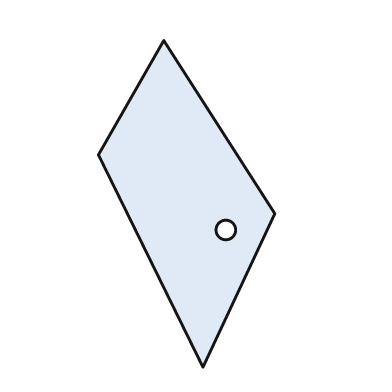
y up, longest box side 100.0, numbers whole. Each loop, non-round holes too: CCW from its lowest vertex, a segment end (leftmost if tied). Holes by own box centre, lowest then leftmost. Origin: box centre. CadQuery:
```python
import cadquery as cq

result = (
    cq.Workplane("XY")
    .moveTo(5.0, -50.0)
    .lineTo(27.0, -3.0)
    .lineTo(-7.0, 50.0)
    .lineTo(-27.0, 15.0)
    .close()
    .moveTo(12.0, -8.0)
    .circle(3.0)
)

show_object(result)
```